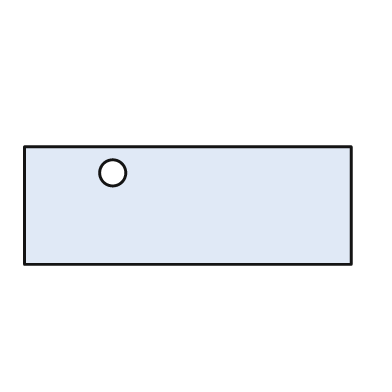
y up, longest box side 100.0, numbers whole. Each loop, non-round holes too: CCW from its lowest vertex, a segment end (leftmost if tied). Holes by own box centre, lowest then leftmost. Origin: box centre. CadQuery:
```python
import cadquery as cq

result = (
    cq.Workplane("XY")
    .moveTo(-50.0, -18.0)
    .lineTo(50.0, -18.0)
    .lineTo(50.0, 18.0)
    .lineTo(-50.0, 18.0)
    .close()
    .moveTo(-23.0, 10.0)
    .circle(4.0)
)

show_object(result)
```